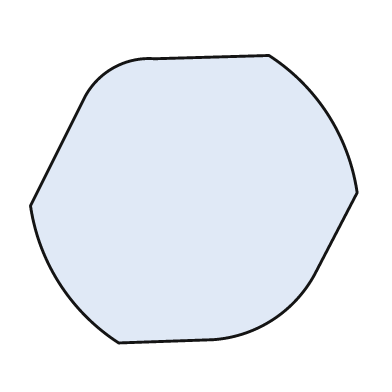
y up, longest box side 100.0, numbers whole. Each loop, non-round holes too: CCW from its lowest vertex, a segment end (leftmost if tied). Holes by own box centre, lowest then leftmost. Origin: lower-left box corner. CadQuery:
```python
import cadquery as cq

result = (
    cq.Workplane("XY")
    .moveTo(27.0, 0.0)
    .lineTo(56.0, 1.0)
    .threePointArc((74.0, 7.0), (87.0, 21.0))
    .lineTo(100.0, 46.0)
    .threePointArc((91.0, 70.0), (73.0, 88.0))
    .lineTo(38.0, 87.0)
    .threePointArc((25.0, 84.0), (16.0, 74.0))
    .lineTo(0.0, 42.0)
    .threePointArc((9.0, 18.0), (27.0, 0.0))
    .close()
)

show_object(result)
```